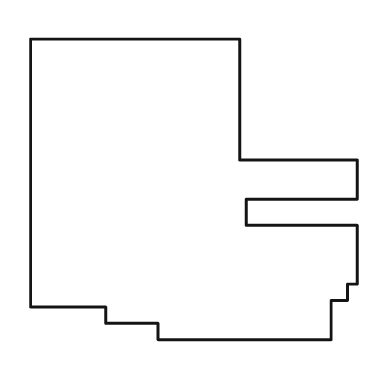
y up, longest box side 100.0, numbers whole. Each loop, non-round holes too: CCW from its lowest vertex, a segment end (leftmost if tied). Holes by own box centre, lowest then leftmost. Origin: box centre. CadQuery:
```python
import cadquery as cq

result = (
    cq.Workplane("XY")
    .moveTo(-11.0, -46.0)
    .lineTo(42.0, -46.0)
    .lineTo(42.0, -34.0)
    .lineTo(47.0, -34.0)
    .lineTo(47.0, -29.0)
    .lineTo(50.0, -29.0)
    .lineTo(50.0, -11.0)
    .lineTo(16.0, -11.0)
    .lineTo(16.0, -3.0)
    .lineTo(50.0, -3.0)
    .lineTo(50.0, 9.0)
    .lineTo(14.0, 9.0)
    .lineTo(14.0, 46.0)
    .lineTo(-50.0, 46.0)
    .lineTo(-50.0, -36.0)
    .lineTo(-27.0, -36.0)
    .lineTo(-27.0, -41.0)
    .lineTo(-11.0, -41.0)
    .close()
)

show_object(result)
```